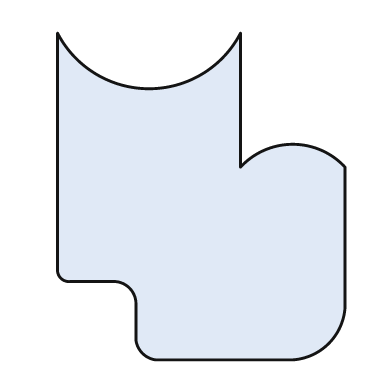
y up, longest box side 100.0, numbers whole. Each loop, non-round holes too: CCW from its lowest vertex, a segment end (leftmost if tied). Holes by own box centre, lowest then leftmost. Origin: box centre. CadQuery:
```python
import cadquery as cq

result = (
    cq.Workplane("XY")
    .moveTo(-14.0, -50.0)
    .lineTo(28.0, -50.0)
    .threePointArc((39.0, -45.0), (44.0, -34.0))
    .lineTo(44.0, 9.0)
    .threePointArc((28.0, 16.0), (12.0, 9.0))
    .lineTo(12.0, 50.0)
    .threePointArc((-16.0, 33.0), (-44.0, 50.0))
    .lineTo(-44.0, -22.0)
    .threePointArc((-43.0, -25.0), (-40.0, -26.0))
    .lineTo(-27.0, -26.0)
    .threePointArc((-22.0, -28.0), (-20.0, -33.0))
    .lineTo(-20.0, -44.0)
    .threePointArc((-18.0, -48.0), (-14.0, -50.0))
    .close()
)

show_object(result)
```